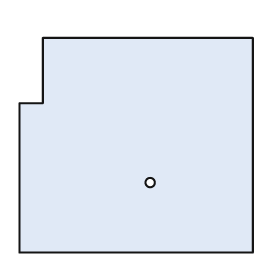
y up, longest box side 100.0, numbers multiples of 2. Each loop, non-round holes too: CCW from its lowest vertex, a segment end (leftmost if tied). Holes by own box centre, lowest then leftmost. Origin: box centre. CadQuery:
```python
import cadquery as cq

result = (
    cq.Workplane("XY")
    .moveTo(-50.0, -46.0)
    .lineTo(50.0, -46.0)
    .lineTo(50.0, 46.0)
    .lineTo(-40.0, 46.0)
    .lineTo(-40.0, 18.0)
    .lineTo(-50.0, 18.0)
    .close()
    .moveTo(6.0, -16.0)
    .circle(2.0)
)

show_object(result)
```